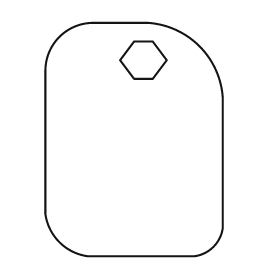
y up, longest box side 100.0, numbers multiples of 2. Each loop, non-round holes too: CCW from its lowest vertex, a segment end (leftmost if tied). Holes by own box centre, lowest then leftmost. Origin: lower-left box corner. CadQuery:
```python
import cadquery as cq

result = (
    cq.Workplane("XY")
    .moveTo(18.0, 0.0)
    .lineTo(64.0, 0.0)
    .threePointArc((72.0, 4.0), (76.0, 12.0))
    .lineTo(76.0, 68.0)
    .threePointArc((66.0, 90.0), (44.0, 100.0))
    .lineTo(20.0, 100.0)
    .threePointArc((6.0, 94.0), (0.0, 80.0))
    .lineTo(0.0, 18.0)
    .threePointArc((6.0, 6.0), (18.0, 0.0))
    .close()
    .moveTo(38.0, 76.0)
    .lineTo(46.0, 76.0)
    .lineTo(52.0, 84.0)
    .lineTo(46.0, 92.0)
    .lineTo(38.0, 92.0)
    .lineTo(32.0, 84.0)
    .close()
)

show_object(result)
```